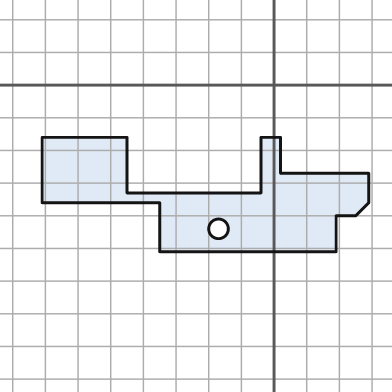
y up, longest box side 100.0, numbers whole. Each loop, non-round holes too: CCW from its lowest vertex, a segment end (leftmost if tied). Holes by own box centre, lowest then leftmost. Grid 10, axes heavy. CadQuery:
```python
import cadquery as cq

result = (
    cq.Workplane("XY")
    .moveTo(-35.0, -51.0)
    .lineTo(19.0, -51.0)
    .lineTo(19.0, -40.0)
    .lineTo(25.0, -40.0)
    .lineTo(29.0, -36.0)
    .lineTo(29.0, -27.0)
    .lineTo(2.0, -27.0)
    .lineTo(2.0, -16.0)
    .lineTo(-4.0, -16.0)
    .lineTo(-4.0, -33.0)
    .lineTo(-45.0, -33.0)
    .lineTo(-45.0, -16.0)
    .lineTo(-71.0, -16.0)
    .lineTo(-71.0, -36.0)
    .lineTo(-35.0, -36.0)
    .close()
    .moveTo(-17.0, -44.0)
    .circle(3.0)
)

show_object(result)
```